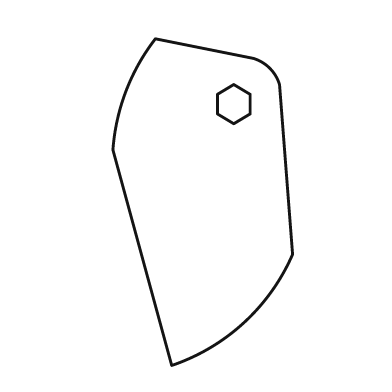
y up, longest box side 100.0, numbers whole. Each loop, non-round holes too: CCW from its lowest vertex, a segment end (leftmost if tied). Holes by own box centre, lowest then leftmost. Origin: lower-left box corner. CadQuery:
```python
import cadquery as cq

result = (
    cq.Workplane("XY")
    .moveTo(18.0, 0.0)
    .threePointArc((40.0, 13.0), (55.0, 34.0))
    .lineTo(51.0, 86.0)
    .threePointArc((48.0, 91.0), (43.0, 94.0))
    .lineTo(13.0, 100.0)
    .threePointArc((4.0, 84.0), (0.0, 66.0))
    .close()
    .moveTo(37.0, 74.0)
    .lineTo(42.0, 77.0)
    .lineTo(42.0, 83.0)
    .lineTo(37.0, 86.0)
    .lineTo(32.0, 83.0)
    .lineTo(32.0, 77.0)
    .close()
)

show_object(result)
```